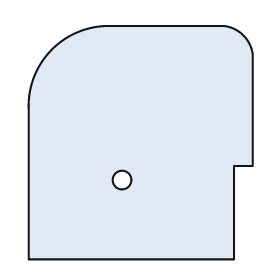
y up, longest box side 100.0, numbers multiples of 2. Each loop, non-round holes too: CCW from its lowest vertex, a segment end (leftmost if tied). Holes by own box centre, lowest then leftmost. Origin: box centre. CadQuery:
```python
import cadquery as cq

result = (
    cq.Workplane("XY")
    .moveTo(-48.0, -50.0)
    .lineTo(40.0, -50.0)
    .lineTo(40.0, -10.0)
    .lineTo(48.0, -10.0)
    .lineTo(48.0, 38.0)
    .threePointArc((44.0, 46.0), (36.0, 50.0))
    .lineTo(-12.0, 50.0)
    .threePointArc((-38.0, 40.0), (-48.0, 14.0))
    .close()
    .moveTo(-8.0, -16.0)
    .circle(4.0)
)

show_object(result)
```